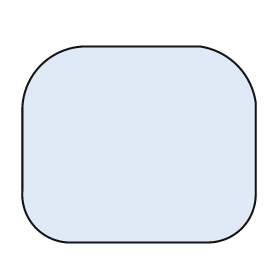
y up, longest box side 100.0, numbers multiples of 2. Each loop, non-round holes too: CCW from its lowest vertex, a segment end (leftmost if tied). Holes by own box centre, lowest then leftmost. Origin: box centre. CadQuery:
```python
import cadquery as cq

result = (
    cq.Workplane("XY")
    .moveTo(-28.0, -42.0)
    .lineTo(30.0, -42.0)
    .threePointArc((44.0, -36.0), (50.0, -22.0))
    .lineTo(50.0, 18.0)
    .threePointArc((42.0, 34.0), (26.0, 42.0))
    .lineTo(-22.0, 42.0)
    .threePointArc((-42.0, 34.0), (-50.0, 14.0))
    .lineTo(-50.0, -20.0)
    .threePointArc((-44.0, -36.0), (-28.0, -42.0))
    .close()
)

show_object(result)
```